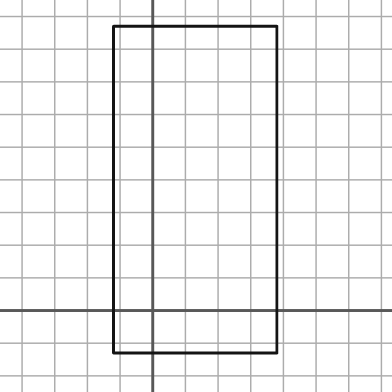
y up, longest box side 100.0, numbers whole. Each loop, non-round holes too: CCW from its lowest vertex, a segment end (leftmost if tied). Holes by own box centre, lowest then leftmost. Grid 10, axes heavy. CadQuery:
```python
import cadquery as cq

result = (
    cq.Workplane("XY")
    .moveTo(-12.0, -13.0)
    .lineTo(38.0, -13.0)
    .lineTo(38.0, 87.0)
    .lineTo(-12.0, 87.0)
    .close()
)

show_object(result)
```